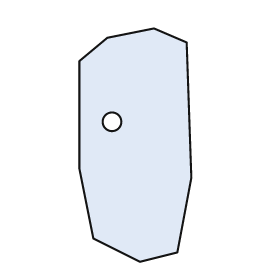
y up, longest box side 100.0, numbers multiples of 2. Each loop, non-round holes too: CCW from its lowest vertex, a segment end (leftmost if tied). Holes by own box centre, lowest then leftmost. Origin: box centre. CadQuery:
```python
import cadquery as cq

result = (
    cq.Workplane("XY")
    .moveTo(2.0, -50.0)
    .lineTo(18.0, -46.0)
    .lineTo(24.0, -14.0)
    .lineTo(22.0, 44.0)
    .lineTo(8.0, 50.0)
    .lineTo(-12.0, 46.0)
    .lineTo(-24.0, 36.0)
    .lineTo(-24.0, -10.0)
    .lineTo(-18.0, -40.0)
    .close()
    .moveTo(-10.0, 10.0)
    .circle(4.0)
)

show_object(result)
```